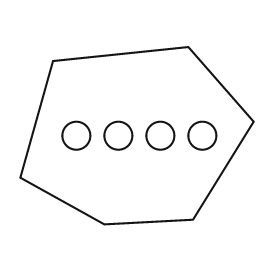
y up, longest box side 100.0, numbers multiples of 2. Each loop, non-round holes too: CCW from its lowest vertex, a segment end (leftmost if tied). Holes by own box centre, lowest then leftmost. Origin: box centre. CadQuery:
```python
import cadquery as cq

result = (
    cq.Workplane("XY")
    .moveTo(-14.0, -38.0)
    .lineTo(24.0, -36.0)
    .lineTo(50.0, 6.0)
    .lineTo(22.0, 38.0)
    .lineTo(-36.0, 32.0)
    .lineTo(-50.0, -18.0)
    .close()
    .moveTo(-26.0, 0.0)
    .circle(6.0)
    .moveTo(-8.0, 0.0)
    .circle(6.0)
    .moveTo(10.0, 0.0)
    .circle(6.0)
    .moveTo(28.0, 0.0)
    .circle(6.0)
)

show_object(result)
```